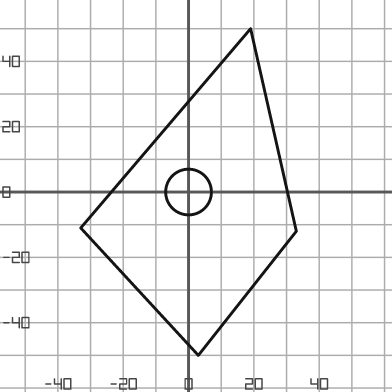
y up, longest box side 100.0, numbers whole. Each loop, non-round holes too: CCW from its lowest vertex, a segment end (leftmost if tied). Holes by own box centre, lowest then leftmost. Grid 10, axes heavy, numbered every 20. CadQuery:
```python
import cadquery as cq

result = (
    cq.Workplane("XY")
    .moveTo(3.0, -50.0)
    .lineTo(33.0, -12.0)
    .lineTo(19.0, 50.0)
    .lineTo(-33.0, -11.0)
    .close()
    .moveTo(0.0, 0.0)
    .circle(7.0)
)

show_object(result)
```